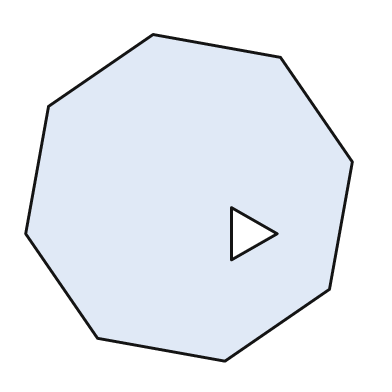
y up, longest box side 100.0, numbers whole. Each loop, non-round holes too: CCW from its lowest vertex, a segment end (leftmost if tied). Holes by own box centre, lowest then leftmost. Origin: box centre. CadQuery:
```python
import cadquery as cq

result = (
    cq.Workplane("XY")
    .moveTo(11.0, -50.0)
    .lineTo(43.0, -28.0)
    .lineTo(50.0, 11.0)
    .lineTo(28.0, 43.0)
    .lineTo(-11.0, 50.0)
    .lineTo(-43.0, 28.0)
    .lineTo(-50.0, -11.0)
    .lineTo(-28.0, -43.0)
    .close()
    .moveTo(13.0, -19.0)
    .lineTo(27.0, -11.0)
    .lineTo(13.0, -3.0)
    .close()
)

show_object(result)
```